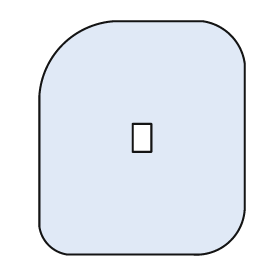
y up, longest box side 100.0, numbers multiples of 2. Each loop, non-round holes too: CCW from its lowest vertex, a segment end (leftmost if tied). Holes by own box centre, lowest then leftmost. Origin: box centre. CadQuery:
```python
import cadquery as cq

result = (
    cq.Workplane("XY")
    .moveTo(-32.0, -50.0)
    .lineTo(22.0, -50.0)
    .threePointArc((38.0, -44.0), (44.0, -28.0))
    .lineTo(44.0, 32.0)
    .threePointArc((38.0, 44.0), (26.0, 50.0))
    .lineTo(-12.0, 50.0)
    .threePointArc((-34.0, 40.0), (-44.0, 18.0))
    .lineTo(-44.0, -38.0)
    .threePointArc((-40.0, -46.0), (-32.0, -50.0))
    .close()
    .moveTo(-4.0, -6.0)
    .lineTo(4.0, -6.0)
    .lineTo(4.0, 6.0)
    .lineTo(-4.0, 6.0)
    .close()
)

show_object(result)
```